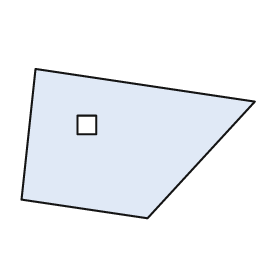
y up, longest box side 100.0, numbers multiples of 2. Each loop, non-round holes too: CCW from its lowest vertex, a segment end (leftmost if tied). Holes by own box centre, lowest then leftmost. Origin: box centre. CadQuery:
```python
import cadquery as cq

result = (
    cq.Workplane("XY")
    .moveTo(4.0, -32.0)
    .lineTo(50.0, 18.0)
    .lineTo(-44.0, 32.0)
    .lineTo(-50.0, -24.0)
    .close()
    .moveTo(-26.0, 4.0)
    .lineTo(-18.0, 4.0)
    .lineTo(-18.0, 12.0)
    .lineTo(-26.0, 12.0)
    .close()
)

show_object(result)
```